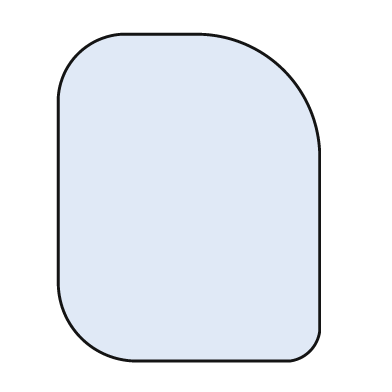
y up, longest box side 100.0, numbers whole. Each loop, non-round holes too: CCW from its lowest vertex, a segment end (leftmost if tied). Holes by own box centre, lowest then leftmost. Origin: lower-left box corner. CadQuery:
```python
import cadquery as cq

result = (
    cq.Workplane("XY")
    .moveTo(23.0, 0.0)
    .lineTo(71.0, 0.0)
    .threePointArc((77.0, 3.0), (80.0, 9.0))
    .lineTo(80.0, 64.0)
    .threePointArc((69.0, 89.0), (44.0, 100.0))
    .lineTo(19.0, 100.0)
    .threePointArc((6.0, 94.0), (0.0, 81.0))
    .lineTo(0.0, 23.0)
    .threePointArc((7.0, 7.0), (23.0, 0.0))
    .close()
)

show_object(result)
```